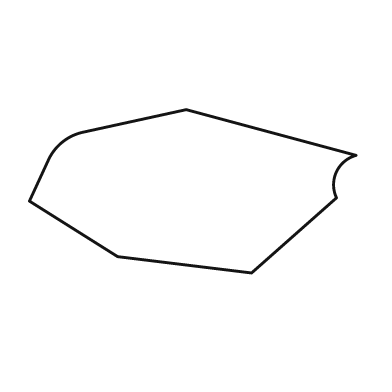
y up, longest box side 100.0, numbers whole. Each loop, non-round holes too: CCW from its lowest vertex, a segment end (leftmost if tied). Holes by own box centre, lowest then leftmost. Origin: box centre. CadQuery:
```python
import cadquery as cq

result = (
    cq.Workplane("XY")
    .moveTo(18.0, -25.0)
    .lineTo(44.0, -2.0)
    .threePointArc((44.0, 6.0), (50.0, 11.0))
    .lineTo(-2.0, 25.0)
    .lineTo(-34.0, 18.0)
    .threePointArc((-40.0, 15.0), (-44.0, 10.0))
    .lineTo(-50.0, -3.0)
    .lineTo(-23.0, -20.0)
    .close()
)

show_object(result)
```